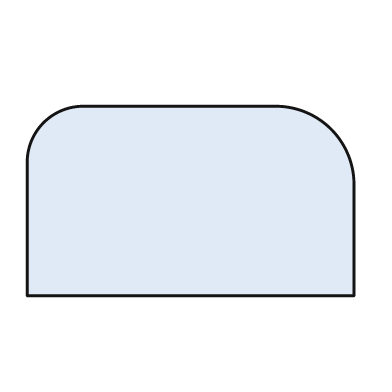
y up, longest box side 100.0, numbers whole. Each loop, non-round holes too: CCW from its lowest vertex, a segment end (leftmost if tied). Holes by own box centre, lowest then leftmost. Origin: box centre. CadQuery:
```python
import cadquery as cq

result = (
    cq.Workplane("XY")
    .moveTo(-50.0, -29.0)
    .lineTo(50.0, -29.0)
    .lineTo(50.0, 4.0)
    .threePointArc((43.0, 22.0), (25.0, 29.0))
    .lineTo(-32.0, 29.0)
    .threePointArc((-45.0, 24.0), (-50.0, 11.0))
    .close()
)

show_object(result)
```